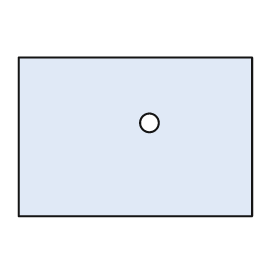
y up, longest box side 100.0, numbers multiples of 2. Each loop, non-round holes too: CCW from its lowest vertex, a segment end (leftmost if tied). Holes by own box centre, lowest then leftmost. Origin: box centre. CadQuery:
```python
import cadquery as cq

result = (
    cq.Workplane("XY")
    .moveTo(-50.0, -34.0)
    .lineTo(50.0, -34.0)
    .lineTo(50.0, 34.0)
    .lineTo(-50.0, 34.0)
    .close()
    .moveTo(6.0, 6.0)
    .circle(4.0)
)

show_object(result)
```